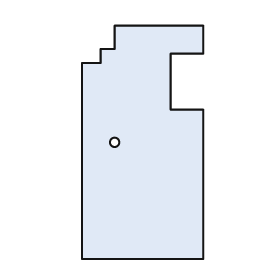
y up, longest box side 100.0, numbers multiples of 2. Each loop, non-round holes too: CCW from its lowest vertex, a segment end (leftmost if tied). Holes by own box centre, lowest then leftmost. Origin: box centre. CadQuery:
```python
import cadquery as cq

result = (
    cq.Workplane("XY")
    .moveTo(-26.0, -50.0)
    .lineTo(26.0, -50.0)
    .lineTo(26.0, 14.0)
    .lineTo(12.0, 14.0)
    .lineTo(12.0, 38.0)
    .lineTo(26.0, 38.0)
    .lineTo(26.0, 50.0)
    .lineTo(-12.0, 50.0)
    .lineTo(-12.0, 40.0)
    .lineTo(-18.0, 40.0)
    .lineTo(-18.0, 34.0)
    .lineTo(-26.0, 34.0)
    .close()
    .moveTo(-12.0, 0.0)
    .circle(2.0)
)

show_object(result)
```